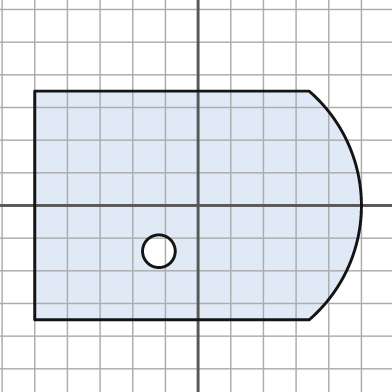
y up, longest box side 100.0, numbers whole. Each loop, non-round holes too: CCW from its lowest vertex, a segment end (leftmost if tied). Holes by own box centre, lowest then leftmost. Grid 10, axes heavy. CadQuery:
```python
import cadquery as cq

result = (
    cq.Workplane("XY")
    .moveTo(-50.0, -35.0)
    .lineTo(34.0, -35.0)
    .threePointArc((50.0, 0.0), (34.0, 35.0))
    .lineTo(-50.0, 35.0)
    .close()
    .moveTo(-12.0, -14.0)
    .circle(5.0)
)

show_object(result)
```